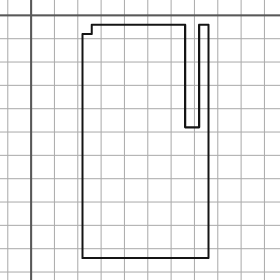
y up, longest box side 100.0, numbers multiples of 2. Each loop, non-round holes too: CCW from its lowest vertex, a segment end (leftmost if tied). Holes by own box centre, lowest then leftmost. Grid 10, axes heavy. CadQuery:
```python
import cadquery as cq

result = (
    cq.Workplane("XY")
    .moveTo(22.0, -104.0)
    .lineTo(76.0, -104.0)
    .lineTo(76.0, -4.0)
    .lineTo(72.0, -4.0)
    .lineTo(72.0, -48.0)
    .lineTo(66.0, -48.0)
    .lineTo(66.0, -4.0)
    .lineTo(26.0, -4.0)
    .lineTo(26.0, -8.0)
    .lineTo(22.0, -8.0)
    .close()
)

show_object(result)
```